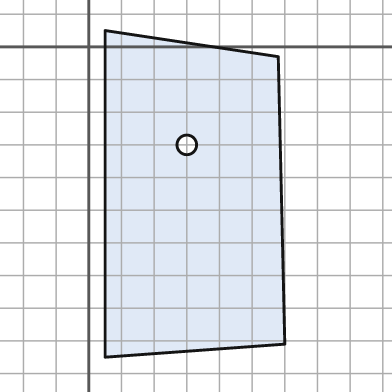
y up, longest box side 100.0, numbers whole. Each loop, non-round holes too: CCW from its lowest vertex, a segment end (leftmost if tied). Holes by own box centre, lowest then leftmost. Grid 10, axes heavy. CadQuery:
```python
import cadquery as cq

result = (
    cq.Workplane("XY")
    .moveTo(5.0, -95.0)
    .lineTo(60.0, -91.0)
    .lineTo(58.0, -3.0)
    .lineTo(5.0, 5.0)
    .close()
    .moveTo(30.0, -30.0)
    .circle(3.0)
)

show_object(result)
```